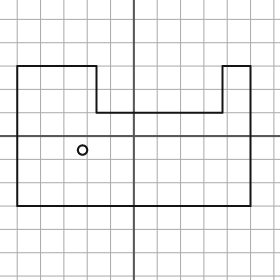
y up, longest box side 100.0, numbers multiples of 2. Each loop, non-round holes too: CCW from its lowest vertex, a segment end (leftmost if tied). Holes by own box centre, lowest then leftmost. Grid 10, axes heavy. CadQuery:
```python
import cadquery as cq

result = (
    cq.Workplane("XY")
    .moveTo(-50.0, -30.0)
    .lineTo(50.0, -30.0)
    .lineTo(50.0, 30.0)
    .lineTo(38.0, 30.0)
    .lineTo(38.0, 10.0)
    .lineTo(-16.0, 10.0)
    .lineTo(-16.0, 30.0)
    .lineTo(-50.0, 30.0)
    .close()
    .moveTo(-22.0, -6.0)
    .circle(2.0)
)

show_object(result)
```